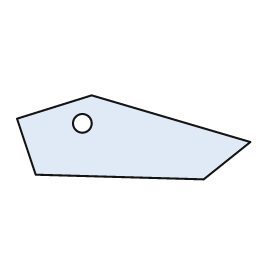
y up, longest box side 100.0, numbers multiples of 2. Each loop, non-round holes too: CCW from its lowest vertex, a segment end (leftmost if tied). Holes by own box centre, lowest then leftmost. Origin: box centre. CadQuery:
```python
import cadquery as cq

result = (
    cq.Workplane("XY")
    .moveTo(30.0, -18.0)
    .lineTo(50.0, -2.0)
    .lineTo(-18.0, 18.0)
    .lineTo(-50.0, 8.0)
    .lineTo(-42.0, -16.0)
    .close()
    .moveTo(-22.0, 6.0)
    .circle(4.0)
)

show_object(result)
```